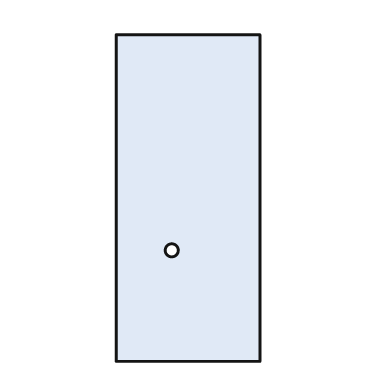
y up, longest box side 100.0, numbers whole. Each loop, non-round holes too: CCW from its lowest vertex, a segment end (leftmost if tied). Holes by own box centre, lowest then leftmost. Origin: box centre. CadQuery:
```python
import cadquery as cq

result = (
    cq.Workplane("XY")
    .moveTo(-22.0, -50.0)
    .lineTo(22.0, -50.0)
    .lineTo(22.0, 50.0)
    .lineTo(-22.0, 50.0)
    .close()
    .moveTo(-5.0, -16.0)
    .circle(2.0)
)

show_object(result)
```